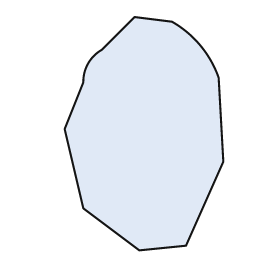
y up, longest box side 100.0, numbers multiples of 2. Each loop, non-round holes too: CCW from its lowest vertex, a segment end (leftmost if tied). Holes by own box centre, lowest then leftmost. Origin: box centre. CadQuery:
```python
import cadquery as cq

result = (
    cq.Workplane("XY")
    .moveTo(-2.0, -50.0)
    .lineTo(18.0, -48.0)
    .lineTo(34.0, -12.0)
    .lineTo(32.0, 24.0)
    .threePointArc((24.0, 38.0), (12.0, 48.0))
    .lineTo(-4.0, 50.0)
    .lineTo(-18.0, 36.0)
    .threePointArc((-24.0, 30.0), (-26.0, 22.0))
    .lineTo(-34.0, 2.0)
    .lineTo(-26.0, -32.0)
    .close()
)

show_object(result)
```